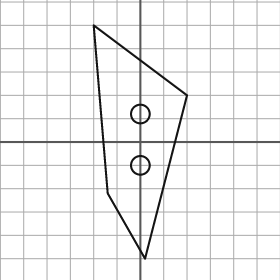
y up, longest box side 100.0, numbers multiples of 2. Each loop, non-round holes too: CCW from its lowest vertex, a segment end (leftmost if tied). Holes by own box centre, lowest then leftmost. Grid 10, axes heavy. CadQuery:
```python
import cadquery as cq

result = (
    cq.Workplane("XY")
    .moveTo(2.0, -50.0)
    .lineTo(20.0, 20.0)
    .lineTo(-20.0, 50.0)
    .lineTo(-14.0, -22.0)
    .close()
    .moveTo(0.0, -10.0)
    .circle(4.0)
    .moveTo(0.0, 12.0)
    .circle(4.0)
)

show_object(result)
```